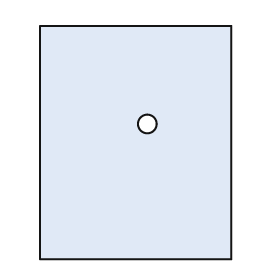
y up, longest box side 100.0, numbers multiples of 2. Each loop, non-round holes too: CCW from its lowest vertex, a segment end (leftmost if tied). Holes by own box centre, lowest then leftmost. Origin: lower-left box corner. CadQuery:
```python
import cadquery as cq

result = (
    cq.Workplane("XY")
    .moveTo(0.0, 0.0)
    .lineTo(82.0, 0.0)
    .lineTo(82.0, 100.0)
    .lineTo(0.0, 100.0)
    .close()
    .moveTo(46.0, 58.0)
    .circle(4.0)
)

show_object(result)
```